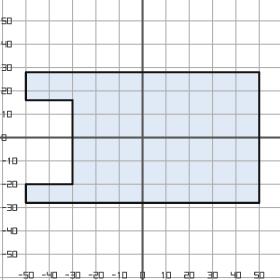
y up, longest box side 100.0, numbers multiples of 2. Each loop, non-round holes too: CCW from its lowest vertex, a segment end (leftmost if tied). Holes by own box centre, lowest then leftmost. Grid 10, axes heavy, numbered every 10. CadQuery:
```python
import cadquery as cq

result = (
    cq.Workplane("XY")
    .moveTo(-50.0, -28.0)
    .lineTo(50.0, -28.0)
    .lineTo(50.0, 28.0)
    .lineTo(-50.0, 28.0)
    .lineTo(-50.0, 16.0)
    .lineTo(-30.0, 16.0)
    .lineTo(-30.0, -20.0)
    .lineTo(-50.0, -20.0)
    .close()
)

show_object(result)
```